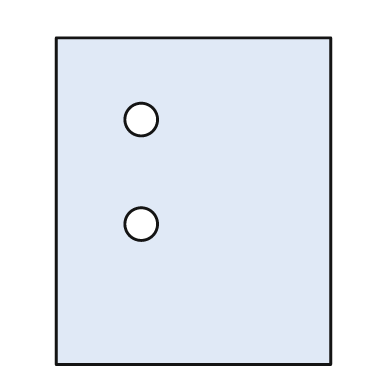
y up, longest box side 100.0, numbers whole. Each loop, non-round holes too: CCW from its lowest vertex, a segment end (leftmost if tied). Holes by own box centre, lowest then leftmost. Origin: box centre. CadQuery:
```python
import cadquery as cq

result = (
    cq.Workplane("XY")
    .moveTo(-42.0, -50.0)
    .lineTo(42.0, -50.0)
    .lineTo(42.0, 50.0)
    .lineTo(-42.0, 50.0)
    .close()
    .moveTo(-16.0, -7.0)
    .circle(5.0)
    .moveTo(-16.0, 25.0)
    .circle(5.0)
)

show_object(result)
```